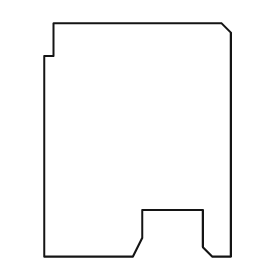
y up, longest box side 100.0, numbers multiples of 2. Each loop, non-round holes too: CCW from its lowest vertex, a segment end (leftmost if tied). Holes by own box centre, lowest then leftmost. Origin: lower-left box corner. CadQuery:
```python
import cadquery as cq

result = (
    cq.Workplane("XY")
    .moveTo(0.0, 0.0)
    .lineTo(38.0, 0.0)
    .lineTo(42.0, 8.0)
    .lineTo(42.0, 20.0)
    .lineTo(68.0, 20.0)
    .lineTo(68.0, 4.0)
    .lineTo(72.0, 0.0)
    .lineTo(80.0, 0.0)
    .lineTo(80.0, 96.0)
    .lineTo(76.0, 100.0)
    .lineTo(4.0, 100.0)
    .lineTo(4.0, 86.0)
    .lineTo(0.0, 86.0)
    .close()
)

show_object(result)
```